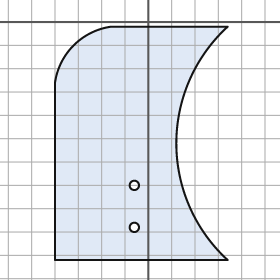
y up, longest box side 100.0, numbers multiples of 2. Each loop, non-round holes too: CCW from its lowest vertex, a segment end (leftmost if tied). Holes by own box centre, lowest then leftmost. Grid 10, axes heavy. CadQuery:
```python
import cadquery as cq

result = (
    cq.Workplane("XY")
    .moveTo(-40.0, -102.0)
    .lineTo(34.0, -102.0)
    .threePointArc((12.0, -52.0), (34.0, -2.0))
    .lineTo(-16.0, -2.0)
    .threePointArc((-32.0, -10.0), (-40.0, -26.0))
    .close()
    .moveTo(-6.0, -88.0)
    .circle(2.0)
    .moveTo(-6.0, -70.0)
    .circle(2.0)
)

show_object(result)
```